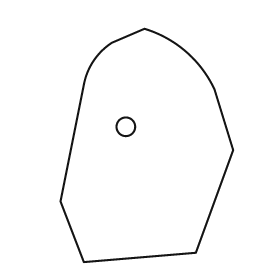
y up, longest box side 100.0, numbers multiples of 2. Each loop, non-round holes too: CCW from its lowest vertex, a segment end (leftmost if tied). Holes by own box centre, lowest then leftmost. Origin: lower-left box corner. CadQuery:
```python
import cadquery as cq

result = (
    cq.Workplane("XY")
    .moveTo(10.0, 0.0)
    .lineTo(58.0, 4.0)
    .lineTo(74.0, 48.0)
    .lineTo(66.0, 74.0)
    .threePointArc((54.0, 90.0), (36.0, 100.0))
    .lineTo(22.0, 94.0)
    .threePointArc((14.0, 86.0), (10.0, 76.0))
    .lineTo(0.0, 26.0)
    .close()
    .moveTo(28.0, 58.0)
    .circle(4.0)
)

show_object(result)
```